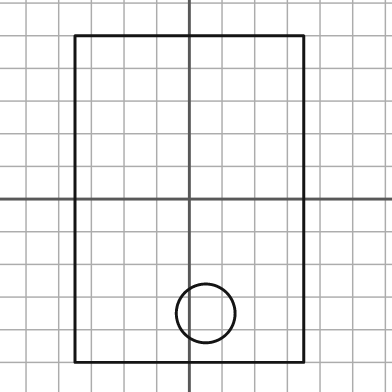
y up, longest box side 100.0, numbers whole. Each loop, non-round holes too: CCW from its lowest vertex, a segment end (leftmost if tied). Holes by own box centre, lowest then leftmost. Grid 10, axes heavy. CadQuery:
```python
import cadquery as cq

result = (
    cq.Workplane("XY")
    .moveTo(-35.0, -50.0)
    .lineTo(35.0, -50.0)
    .lineTo(35.0, 50.0)
    .lineTo(-35.0, 50.0)
    .close()
    .moveTo(5.0, -35.0)
    .circle(9.0)
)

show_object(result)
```